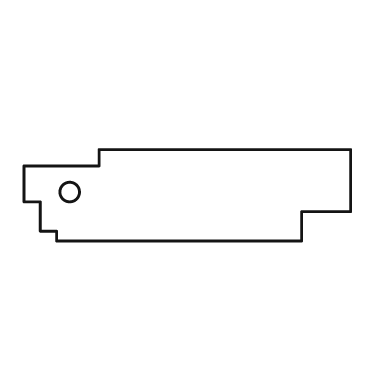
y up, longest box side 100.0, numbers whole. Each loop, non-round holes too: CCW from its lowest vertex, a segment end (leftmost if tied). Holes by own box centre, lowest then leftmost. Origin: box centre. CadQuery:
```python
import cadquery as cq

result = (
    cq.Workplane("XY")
    .moveTo(-40.0, -14.0)
    .lineTo(35.0, -14.0)
    .lineTo(35.0, -5.0)
    .lineTo(50.0, -5.0)
    .lineTo(50.0, 14.0)
    .lineTo(-27.0, 14.0)
    .lineTo(-27.0, 9.0)
    .lineTo(-50.0, 9.0)
    .lineTo(-50.0, -2.0)
    .lineTo(-45.0, -2.0)
    .lineTo(-45.0, -11.0)
    .lineTo(-40.0, -11.0)
    .close()
    .moveTo(-36.0, 1.0)
    .circle(3.0)
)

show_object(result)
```